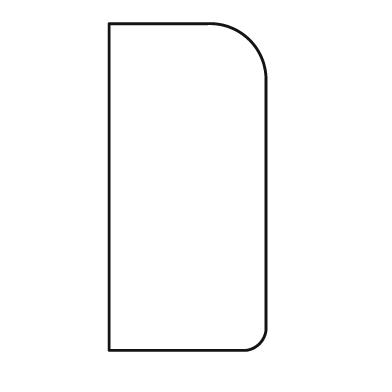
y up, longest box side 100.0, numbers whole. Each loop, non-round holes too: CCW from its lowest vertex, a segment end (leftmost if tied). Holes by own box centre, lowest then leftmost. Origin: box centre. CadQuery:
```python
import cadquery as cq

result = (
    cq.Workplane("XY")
    .moveTo(-24.0, -50.0)
    .lineTo(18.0, -50.0)
    .threePointArc((22.0, -48.0), (24.0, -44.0))
    .lineTo(24.0, 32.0)
    .threePointArc((19.0, 45.0), (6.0, 50.0))
    .lineTo(-24.0, 50.0)
    .close()
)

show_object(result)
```